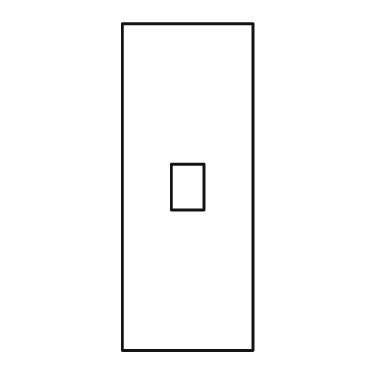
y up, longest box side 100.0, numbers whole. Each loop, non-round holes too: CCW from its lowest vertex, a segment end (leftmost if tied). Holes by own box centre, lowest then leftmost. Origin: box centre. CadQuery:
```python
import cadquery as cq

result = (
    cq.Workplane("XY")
    .moveTo(-20.0, -50.0)
    .lineTo(20.0, -50.0)
    .lineTo(20.0, 50.0)
    .lineTo(-20.0, 50.0)
    .close()
    .moveTo(-5.0, -7.0)
    .lineTo(5.0, -7.0)
    .lineTo(5.0, 7.0)
    .lineTo(-5.0, 7.0)
    .close()
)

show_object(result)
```